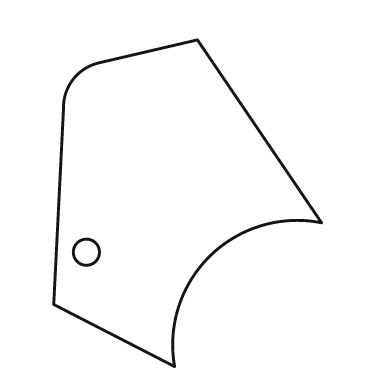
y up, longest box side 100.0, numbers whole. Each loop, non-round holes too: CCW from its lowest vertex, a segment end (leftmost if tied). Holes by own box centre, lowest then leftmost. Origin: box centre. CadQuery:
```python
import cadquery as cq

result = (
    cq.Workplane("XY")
    .moveTo(-4.0, -50.0)
    .threePointArc((7.0, -16.0), (41.0, -6.0))
    .lineTo(3.0, 50.0)
    .lineTo(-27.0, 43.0)
    .threePointArc((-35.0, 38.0), (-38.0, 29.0))
    .lineTo(-41.0, -31.0)
    .close()
    .moveTo(-31.0, -15.0)
    .circle(4.0)
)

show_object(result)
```